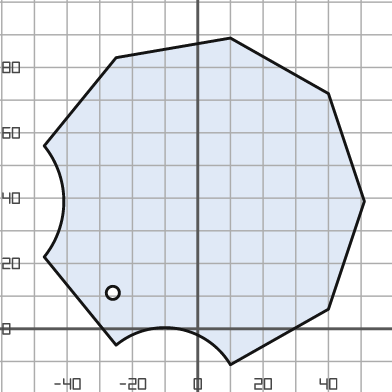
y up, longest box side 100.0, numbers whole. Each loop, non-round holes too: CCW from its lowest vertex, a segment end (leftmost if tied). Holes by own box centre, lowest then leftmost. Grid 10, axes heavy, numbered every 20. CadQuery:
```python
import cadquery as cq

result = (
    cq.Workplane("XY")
    .moveTo(10.0, -11.0)
    .lineTo(40.0, 6.0)
    .lineTo(51.0, 39.0)
    .lineTo(40.0, 72.0)
    .lineTo(10.0, 89.0)
    .lineTo(-25.0, 83.0)
    .lineTo(-47.0, 56.0)
    .threePointArc((-41.0, 39.0), (-47.0, 22.0))
    .lineTo(-25.0, -5.0)
    .threePointArc((-6.0, 0.0), (10.0, -11.0))
    .close()
    .moveTo(-26.0, 11.0)
    .circle(2.0)
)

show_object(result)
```